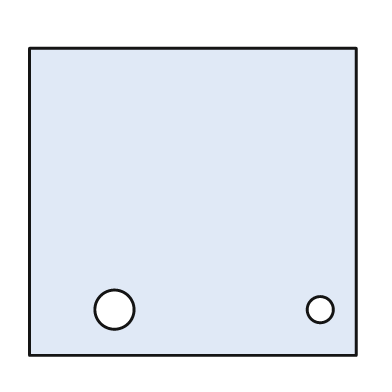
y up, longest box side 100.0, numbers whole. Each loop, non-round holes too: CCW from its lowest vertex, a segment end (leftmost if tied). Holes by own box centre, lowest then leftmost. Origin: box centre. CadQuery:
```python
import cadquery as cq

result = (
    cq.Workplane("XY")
    .moveTo(-50.0, -47.0)
    .lineTo(50.0, -47.0)
    .lineTo(50.0, 47.0)
    .lineTo(-50.0, 47.0)
    .close()
    .moveTo(-24.0, -33.0)
    .circle(6.0)
    .moveTo(39.0, -33.0)
    .circle(4.0)
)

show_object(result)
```